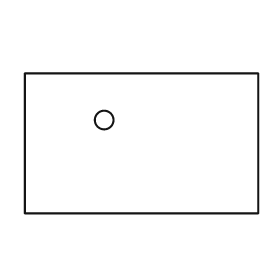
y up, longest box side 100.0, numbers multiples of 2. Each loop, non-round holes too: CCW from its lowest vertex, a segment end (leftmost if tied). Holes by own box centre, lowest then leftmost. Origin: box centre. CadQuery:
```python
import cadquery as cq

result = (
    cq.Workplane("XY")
    .moveTo(-50.0, -30.0)
    .lineTo(50.0, -30.0)
    .lineTo(50.0, 30.0)
    .lineTo(-50.0, 30.0)
    .close()
    .moveTo(-16.0, 10.0)
    .circle(4.0)
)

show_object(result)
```